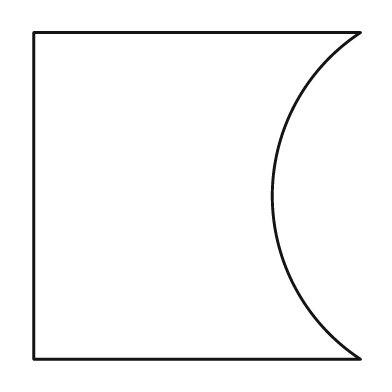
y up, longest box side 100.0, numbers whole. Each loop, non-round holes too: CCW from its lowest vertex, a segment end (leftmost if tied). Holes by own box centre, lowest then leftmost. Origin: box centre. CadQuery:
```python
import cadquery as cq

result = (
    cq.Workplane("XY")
    .moveTo(-50.0, -50.0)
    .lineTo(50.0, -50.0)
    .threePointArc((23.0, 0.0), (50.0, 50.0))
    .lineTo(-50.0, 50.0)
    .close()
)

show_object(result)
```